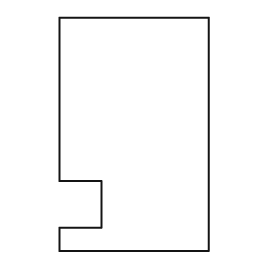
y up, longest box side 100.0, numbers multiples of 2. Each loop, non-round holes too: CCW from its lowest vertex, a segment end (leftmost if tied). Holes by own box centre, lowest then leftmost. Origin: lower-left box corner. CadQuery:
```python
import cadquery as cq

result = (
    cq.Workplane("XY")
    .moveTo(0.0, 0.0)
    .lineTo(64.0, 0.0)
    .lineTo(64.0, 100.0)
    .lineTo(0.0, 100.0)
    .lineTo(0.0, 30.0)
    .lineTo(18.0, 30.0)
    .lineTo(18.0, 10.0)
    .lineTo(0.0, 10.0)
    .close()
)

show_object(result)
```